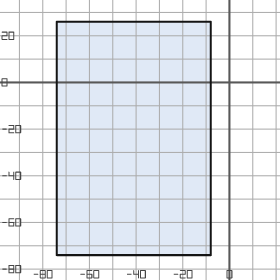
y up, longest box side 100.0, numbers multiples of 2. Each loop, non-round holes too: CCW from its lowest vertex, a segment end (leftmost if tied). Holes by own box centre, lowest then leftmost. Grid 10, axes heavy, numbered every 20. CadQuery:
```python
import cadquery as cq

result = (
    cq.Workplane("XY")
    .moveTo(-74.0, -74.0)
    .lineTo(-8.0, -74.0)
    .lineTo(-8.0, 26.0)
    .lineTo(-74.0, 26.0)
    .close()
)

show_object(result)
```